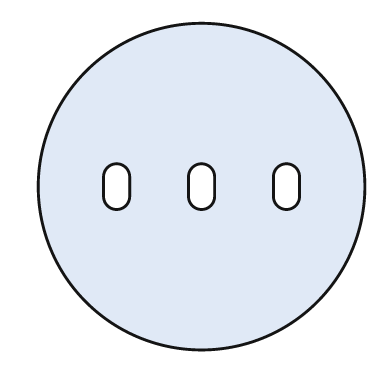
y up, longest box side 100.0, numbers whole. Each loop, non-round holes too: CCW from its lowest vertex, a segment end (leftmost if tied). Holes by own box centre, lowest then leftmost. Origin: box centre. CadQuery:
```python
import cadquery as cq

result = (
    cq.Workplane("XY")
    .moveTo(0.0, 0.0)
    .circle(50.0)
    .moveTo(-30.0, -3.0)
    .threePointArc((-26.0, -7.0), (-22.0, -3.0))
    .lineTo(-22.0, 3.0)
    .threePointArc((-26.0, 7.0), (-30.0, 3.0))
    .close()
    .moveTo(-4.0, -3.0)
    .threePointArc((0.0, -7.0), (4.0, -3.0))
    .lineTo(4.0, 3.0)
    .threePointArc((0.0, 7.0), (-4.0, 3.0))
    .close()
    .moveTo(22.0, -3.0)
    .threePointArc((26.0, -7.0), (30.0, -3.0))
    .lineTo(30.0, 3.0)
    .threePointArc((26.0, 7.0), (22.0, 3.0))
    .close()
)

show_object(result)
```